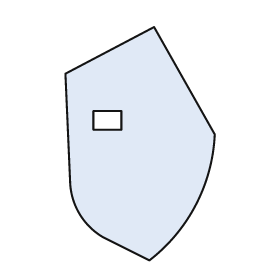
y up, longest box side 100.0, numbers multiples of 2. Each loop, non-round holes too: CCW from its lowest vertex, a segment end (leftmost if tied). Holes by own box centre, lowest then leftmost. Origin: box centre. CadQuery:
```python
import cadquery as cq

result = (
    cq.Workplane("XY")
    .moveTo(4.0, -50.0)
    .threePointArc((24.0, -26.0), (32.0, 4.0))
    .lineTo(6.0, 50.0)
    .lineTo(-32.0, 30.0)
    .lineTo(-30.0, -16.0)
    .threePointArc((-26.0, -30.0), (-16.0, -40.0))
    .close()
    .moveTo(-20.0, 6.0)
    .lineTo(-8.0, 6.0)
    .lineTo(-8.0, 14.0)
    .lineTo(-20.0, 14.0)
    .close()
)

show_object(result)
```